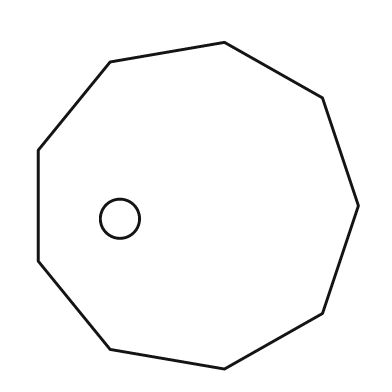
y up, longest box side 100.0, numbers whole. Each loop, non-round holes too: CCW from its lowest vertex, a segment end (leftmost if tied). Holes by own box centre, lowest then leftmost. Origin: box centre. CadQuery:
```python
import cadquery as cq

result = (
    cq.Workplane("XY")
    .moveTo(8.0, -50.0)
    .lineTo(38.0, -33.0)
    .lineTo(49.0, 0.0)
    .lineTo(38.0, 33.0)
    .lineTo(8.0, 50.0)
    .lineTo(-27.0, 44.0)
    .lineTo(-49.0, 17.0)
    .lineTo(-49.0, -17.0)
    .lineTo(-27.0, -44.0)
    .close()
    .moveTo(-24.0, -4.0)
    .circle(6.0)
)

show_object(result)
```